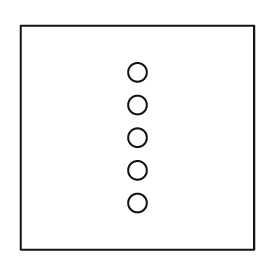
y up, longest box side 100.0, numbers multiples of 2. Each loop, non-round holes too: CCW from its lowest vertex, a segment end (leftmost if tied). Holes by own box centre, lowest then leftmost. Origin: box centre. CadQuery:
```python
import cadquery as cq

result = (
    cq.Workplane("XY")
    .moveTo(-50.0, -48.0)
    .lineTo(50.0, -48.0)
    .lineTo(50.0, 48.0)
    .lineTo(-50.0, 48.0)
    .close()
    .moveTo(0.0, -28.0)
    .circle(4.0)
    .moveTo(0.0, -14.0)
    .circle(4.0)
    .moveTo(0.0, 0.0)
    .circle(4.0)
    .moveTo(0.0, 14.0)
    .circle(4.0)
    .moveTo(0.0, 28.0)
    .circle(4.0)
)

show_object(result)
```